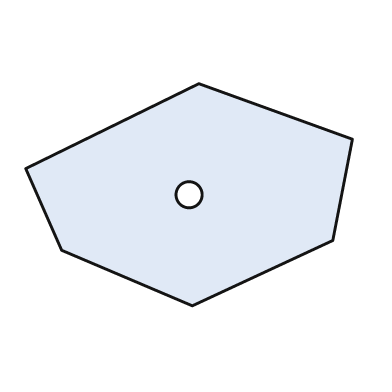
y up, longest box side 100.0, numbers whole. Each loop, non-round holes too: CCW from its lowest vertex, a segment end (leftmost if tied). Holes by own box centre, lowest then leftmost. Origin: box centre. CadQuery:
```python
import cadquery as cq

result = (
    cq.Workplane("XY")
    .moveTo(1.0, -34.0)
    .lineTo(44.0, -14.0)
    .lineTo(50.0, 17.0)
    .lineTo(3.0, 34.0)
    .lineTo(-50.0, 8.0)
    .lineTo(-39.0, -17.0)
    .close()
    .moveTo(0.0, 0.0)
    .circle(4.0)
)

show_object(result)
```